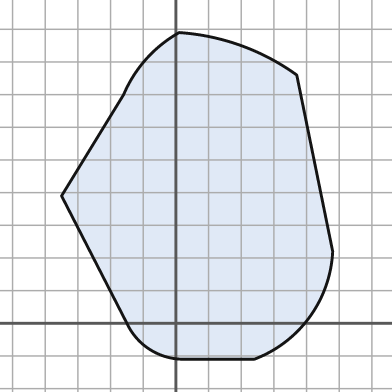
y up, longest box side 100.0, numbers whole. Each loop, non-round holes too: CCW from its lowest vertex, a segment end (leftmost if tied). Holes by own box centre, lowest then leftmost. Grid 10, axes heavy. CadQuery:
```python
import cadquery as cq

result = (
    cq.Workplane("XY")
    .moveTo(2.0, -11.0)
    .lineTo(24.0, -11.0)
    .threePointArc((41.0, 2.0), (48.0, 22.0))
    .lineTo(37.0, 76.0)
    .threePointArc((20.0, 85.0), (1.0, 89.0))
    .threePointArc((-9.0, 81.0), (-16.0, 70.0))
    .lineTo(-35.0, 39.0)
    .lineTo(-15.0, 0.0)
    .threePointArc((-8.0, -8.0), (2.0, -11.0))
    .close()
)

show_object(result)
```